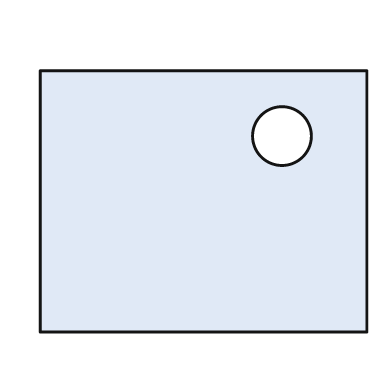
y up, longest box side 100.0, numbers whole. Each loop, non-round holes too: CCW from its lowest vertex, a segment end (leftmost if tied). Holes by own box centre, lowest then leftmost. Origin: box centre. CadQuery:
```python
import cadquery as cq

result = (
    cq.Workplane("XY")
    .moveTo(-50.0, -40.0)
    .lineTo(50.0, -40.0)
    .lineTo(50.0, 40.0)
    .lineTo(-50.0, 40.0)
    .close()
    .moveTo(24.0, 20.0)
    .circle(9.0)
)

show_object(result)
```